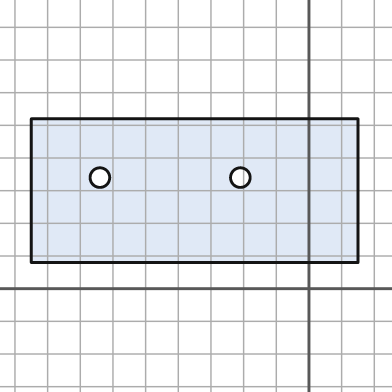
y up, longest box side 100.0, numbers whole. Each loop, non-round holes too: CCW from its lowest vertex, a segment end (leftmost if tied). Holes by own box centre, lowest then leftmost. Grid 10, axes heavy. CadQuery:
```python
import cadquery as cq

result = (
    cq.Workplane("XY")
    .moveTo(-85.0, 8.0)
    .lineTo(15.0, 8.0)
    .lineTo(15.0, 52.0)
    .lineTo(-85.0, 52.0)
    .close()
    .moveTo(-64.0, 34.0)
    .circle(3.0)
    .moveTo(-21.0, 34.0)
    .circle(3.0)
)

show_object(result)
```